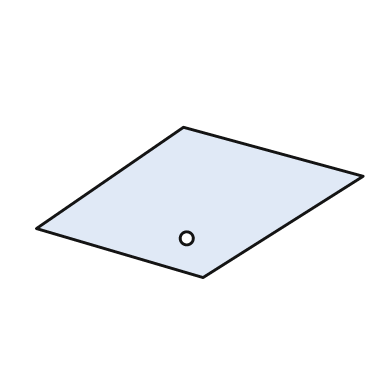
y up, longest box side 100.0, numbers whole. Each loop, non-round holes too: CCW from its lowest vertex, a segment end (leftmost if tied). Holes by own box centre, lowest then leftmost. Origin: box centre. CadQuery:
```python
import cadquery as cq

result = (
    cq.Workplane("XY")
    .moveTo(1.0, -23.0)
    .lineTo(50.0, 8.0)
    .lineTo(-5.0, 23.0)
    .lineTo(-50.0, -8.0)
    .close()
    .moveTo(-4.0, -11.0)
    .circle(2.0)
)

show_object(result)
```